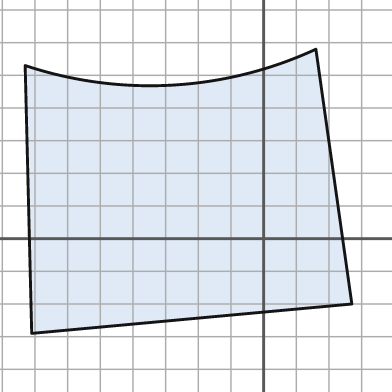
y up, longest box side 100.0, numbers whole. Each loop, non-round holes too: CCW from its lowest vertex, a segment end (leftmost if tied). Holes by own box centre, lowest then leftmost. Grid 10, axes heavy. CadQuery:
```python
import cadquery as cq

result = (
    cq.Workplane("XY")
    .moveTo(-71.0, -29.0)
    .lineTo(27.0, -20.0)
    .lineTo(16.0, 58.0)
    .threePointArc((-28.0, 47.0), (-73.0, 53.0))
    .close()
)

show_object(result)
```